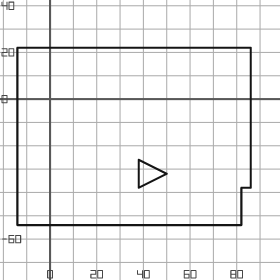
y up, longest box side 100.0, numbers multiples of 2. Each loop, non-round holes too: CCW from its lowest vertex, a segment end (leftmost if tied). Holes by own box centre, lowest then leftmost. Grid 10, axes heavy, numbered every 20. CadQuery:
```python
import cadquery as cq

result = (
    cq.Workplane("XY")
    .moveTo(-14.0, -54.0)
    .lineTo(82.0, -54.0)
    .lineTo(82.0, -38.0)
    .lineTo(86.0, -38.0)
    .lineTo(86.0, 22.0)
    .lineTo(-14.0, 22.0)
    .close()
    .moveTo(38.0, -38.0)
    .lineTo(50.0, -32.0)
    .lineTo(38.0, -26.0)
    .close()
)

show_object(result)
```